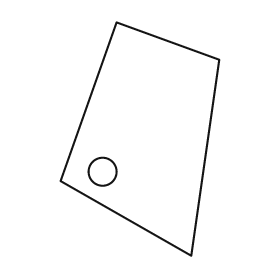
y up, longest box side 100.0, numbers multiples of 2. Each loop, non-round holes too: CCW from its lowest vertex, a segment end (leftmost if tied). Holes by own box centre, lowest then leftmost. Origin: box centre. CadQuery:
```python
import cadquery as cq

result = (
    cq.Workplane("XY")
    .moveTo(22.0, -50.0)
    .lineTo(34.0, 34.0)
    .lineTo(-10.0, 50.0)
    .lineTo(-34.0, -18.0)
    .close()
    .moveTo(-16.0, -14.0)
    .circle(6.0)
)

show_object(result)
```